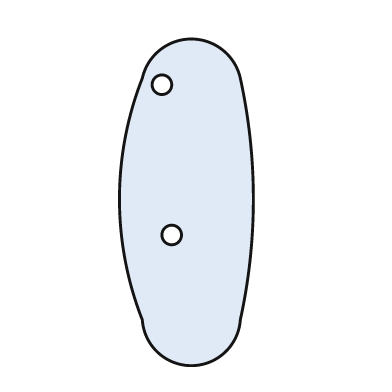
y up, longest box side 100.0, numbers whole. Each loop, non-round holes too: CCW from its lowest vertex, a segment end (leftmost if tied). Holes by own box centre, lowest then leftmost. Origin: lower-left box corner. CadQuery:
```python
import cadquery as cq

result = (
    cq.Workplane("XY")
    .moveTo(7.0, 14.0)
    .threePointArc((22.0, 0.0), (37.0, 14.0))
    .threePointArc((41.0, 51.0), (37.0, 88.0))
    .threePointArc((22.0, 100.0), (7.0, 88.0))
    .threePointArc((0.0, 51.0), (7.0, 14.0))
    .close()
    .moveTo(16.0, 40.0)
    .circle(3.0)
    .moveTo(13.0, 86.0)
    .circle(3.0)
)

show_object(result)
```